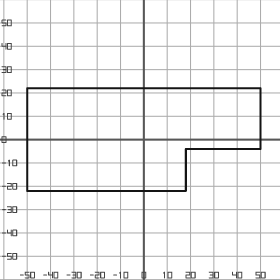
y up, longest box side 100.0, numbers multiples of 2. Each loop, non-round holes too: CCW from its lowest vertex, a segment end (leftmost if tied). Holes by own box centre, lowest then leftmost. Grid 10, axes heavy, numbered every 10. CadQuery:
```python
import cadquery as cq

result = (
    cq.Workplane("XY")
    .moveTo(-50.0, -22.0)
    .lineTo(18.0, -22.0)
    .lineTo(18.0, -4.0)
    .lineTo(50.0, -4.0)
    .lineTo(50.0, 22.0)
    .lineTo(-50.0, 22.0)
    .close()
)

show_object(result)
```